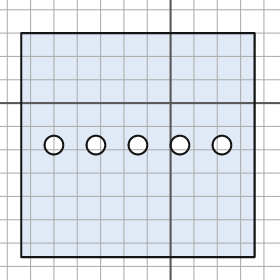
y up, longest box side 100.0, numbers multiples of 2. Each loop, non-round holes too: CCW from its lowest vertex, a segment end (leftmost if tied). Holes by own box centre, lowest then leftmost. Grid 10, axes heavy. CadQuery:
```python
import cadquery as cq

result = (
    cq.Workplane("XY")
    .moveTo(-64.0, -66.0)
    .lineTo(36.0, -66.0)
    .lineTo(36.0, 30.0)
    .lineTo(-64.0, 30.0)
    .close()
    .moveTo(-50.0, -18.0)
    .circle(4.0)
    .moveTo(-32.0, -18.0)
    .circle(4.0)
    .moveTo(-14.0, -18.0)
    .circle(4.0)
    .moveTo(4.0, -18.0)
    .circle(4.0)
    .moveTo(22.0, -18.0)
    .circle(4.0)
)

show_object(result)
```